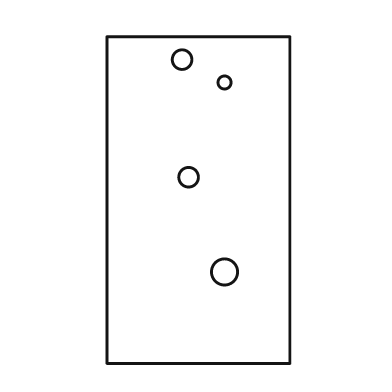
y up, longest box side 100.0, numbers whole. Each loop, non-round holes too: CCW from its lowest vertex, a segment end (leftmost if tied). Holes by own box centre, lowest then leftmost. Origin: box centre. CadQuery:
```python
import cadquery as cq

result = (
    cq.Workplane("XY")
    .moveTo(-28.0, -50.0)
    .lineTo(28.0, -50.0)
    .lineTo(28.0, 50.0)
    .lineTo(-28.0, 50.0)
    .close()
    .moveTo(8.0, -22.0)
    .circle(4.0)
    .moveTo(-3.0, 7.0)
    .circle(3.0)
    .moveTo(8.0, 36.0)
    .circle(2.0)
    .moveTo(-5.0, 43.0)
    .circle(3.0)
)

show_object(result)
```